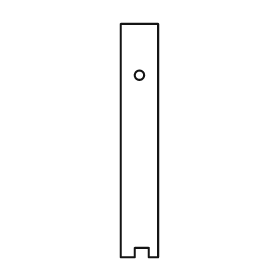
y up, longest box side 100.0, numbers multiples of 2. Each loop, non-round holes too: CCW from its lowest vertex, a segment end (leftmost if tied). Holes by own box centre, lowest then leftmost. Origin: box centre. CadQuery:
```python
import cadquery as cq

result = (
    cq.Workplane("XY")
    .moveTo(-8.0, -50.0)
    .lineTo(-2.0, -50.0)
    .lineTo(-2.0, -46.0)
    .lineTo(4.0, -46.0)
    .lineTo(4.0, -50.0)
    .lineTo(8.0, -50.0)
    .lineTo(8.0, 50.0)
    .lineTo(-8.0, 50.0)
    .close()
    .moveTo(0.0, 28.0)
    .circle(2.0)
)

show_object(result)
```